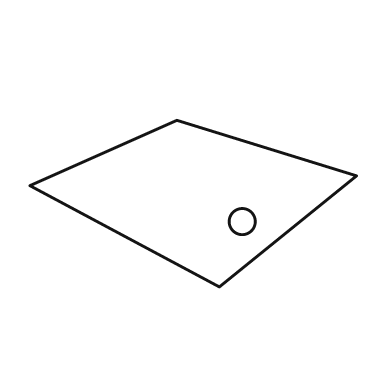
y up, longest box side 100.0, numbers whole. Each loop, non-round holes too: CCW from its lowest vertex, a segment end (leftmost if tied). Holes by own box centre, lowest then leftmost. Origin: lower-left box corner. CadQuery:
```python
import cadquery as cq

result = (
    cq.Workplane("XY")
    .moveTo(58.0, 0.0)
    .lineTo(100.0, 34.0)
    .lineTo(45.0, 51.0)
    .lineTo(0.0, 31.0)
    .close()
    .moveTo(65.0, 20.0)
    .circle(4.0)
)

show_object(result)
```